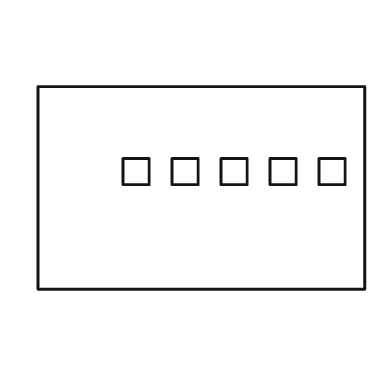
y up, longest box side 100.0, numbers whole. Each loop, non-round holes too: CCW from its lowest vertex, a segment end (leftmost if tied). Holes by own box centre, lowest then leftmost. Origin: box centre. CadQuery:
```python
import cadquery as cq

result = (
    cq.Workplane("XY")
    .moveTo(-50.0, -31.0)
    .lineTo(50.0, -31.0)
    .lineTo(50.0, 31.0)
    .lineTo(-50.0, 31.0)
    .close()
    .moveTo(-24.0, 1.0)
    .lineTo(-16.0, 1.0)
    .lineTo(-16.0, 9.0)
    .lineTo(-24.0, 9.0)
    .close()
    .moveTo(-9.0, 1.0)
    .lineTo(-1.0, 1.0)
    .lineTo(-1.0, 9.0)
    .lineTo(-9.0, 9.0)
    .close()
    .moveTo(6.0, 1.0)
    .lineTo(14.0, 1.0)
    .lineTo(14.0, 9.0)
    .lineTo(6.0, 9.0)
    .close()
    .moveTo(21.0, 1.0)
    .lineTo(29.0, 1.0)
    .lineTo(29.0, 9.0)
    .lineTo(21.0, 9.0)
    .close()
    .moveTo(36.0, 1.0)
    .lineTo(44.0, 1.0)
    .lineTo(44.0, 9.0)
    .lineTo(36.0, 9.0)
    .close()
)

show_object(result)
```